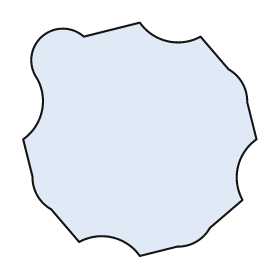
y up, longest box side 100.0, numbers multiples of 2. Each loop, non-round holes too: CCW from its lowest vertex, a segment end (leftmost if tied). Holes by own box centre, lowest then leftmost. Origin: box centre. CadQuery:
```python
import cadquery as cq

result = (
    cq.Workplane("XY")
    .moveTo(0.0, -50.0)
    .lineTo(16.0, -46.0)
    .threePointArc((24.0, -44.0), (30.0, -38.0))
    .lineTo(44.0, -26.0)
    .threePointArc((42.0, -12.0), (50.0, 0.0))
    .lineTo(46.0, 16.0)
    .threePointArc((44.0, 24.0), (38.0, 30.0))
    .lineTo(26.0, 44.0)
    .threePointArc((12.0, 42.0), (0.0, 50.0))
    .lineTo(-24.0, 44.0)
    .threePointArc((-42.0, 44.0), (-44.0, 26.0))
    .threePointArc((-42.0, 12.0), (-50.0, 0.0))
    .lineTo(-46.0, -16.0)
    .threePointArc((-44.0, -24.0), (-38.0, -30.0))
    .lineTo(-26.0, -44.0)
    .threePointArc((-12.0, -42.0), (0.0, -50.0))
    .close()
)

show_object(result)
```